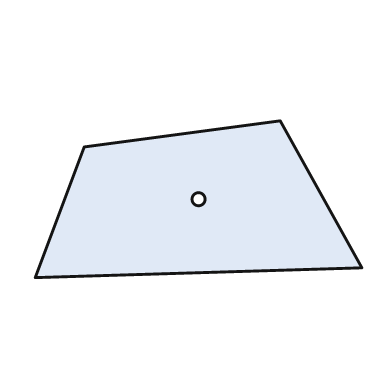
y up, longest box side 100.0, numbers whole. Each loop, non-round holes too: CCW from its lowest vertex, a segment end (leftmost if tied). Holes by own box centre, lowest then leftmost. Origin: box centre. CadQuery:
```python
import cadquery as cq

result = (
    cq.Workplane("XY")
    .moveTo(-50.0, -24.0)
    .lineTo(50.0, -21.0)
    .lineTo(25.0, 24.0)
    .lineTo(-35.0, 16.0)
    .close()
    .moveTo(0.0, 0.0)
    .circle(2.0)
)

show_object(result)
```